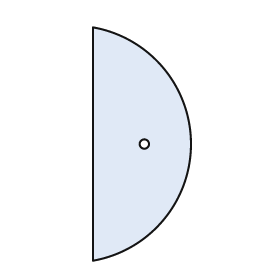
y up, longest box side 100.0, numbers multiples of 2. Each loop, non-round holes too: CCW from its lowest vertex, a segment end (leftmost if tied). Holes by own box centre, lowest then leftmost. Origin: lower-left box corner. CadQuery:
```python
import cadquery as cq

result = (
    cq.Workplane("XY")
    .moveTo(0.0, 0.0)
    .threePointArc((42.0, 50.0), (0.0, 100.0))
    .close()
    .moveTo(22.0, 50.0)
    .circle(2.0)
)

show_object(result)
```